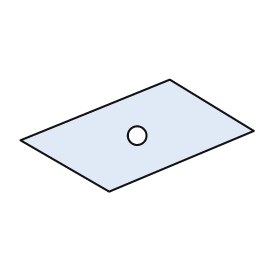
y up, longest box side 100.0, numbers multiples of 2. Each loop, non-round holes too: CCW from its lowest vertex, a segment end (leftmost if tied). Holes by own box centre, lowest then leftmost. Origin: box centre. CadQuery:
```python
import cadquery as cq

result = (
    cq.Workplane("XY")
    .moveTo(-12.0, -24.0)
    .lineTo(50.0, 2.0)
    .lineTo(14.0, 24.0)
    .lineTo(-50.0, -2.0)
    .close()
    .moveTo(0.0, 0.0)
    .circle(4.0)
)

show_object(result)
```